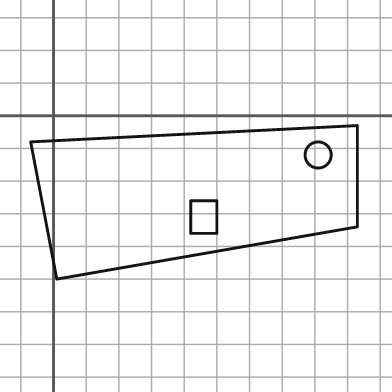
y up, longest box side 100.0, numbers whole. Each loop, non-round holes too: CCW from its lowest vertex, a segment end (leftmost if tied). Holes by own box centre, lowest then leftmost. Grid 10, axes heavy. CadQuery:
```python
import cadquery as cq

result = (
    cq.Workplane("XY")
    .moveTo(1.0, -50.0)
    .lineTo(93.0, -34.0)
    .lineTo(93.0, -3.0)
    .lineTo(-7.0, -8.0)
    .close()
    .moveTo(42.0, -36.0)
    .lineTo(50.0, -36.0)
    .lineTo(50.0, -26.0)
    .lineTo(42.0, -26.0)
    .close()
    .moveTo(81.0, -12.0)
    .circle(4.0)
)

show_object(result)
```